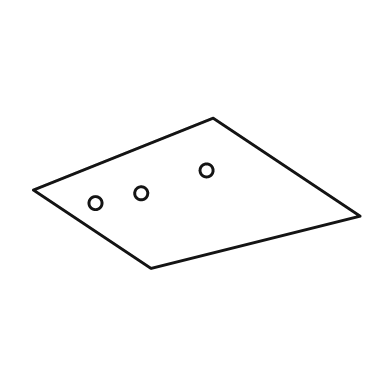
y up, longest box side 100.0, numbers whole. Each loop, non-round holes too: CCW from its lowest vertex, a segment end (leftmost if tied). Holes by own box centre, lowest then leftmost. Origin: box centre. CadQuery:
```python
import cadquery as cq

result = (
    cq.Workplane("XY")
    .moveTo(-14.0, -23.0)
    .lineTo(50.0, -7.0)
    .lineTo(5.0, 23.0)
    .lineTo(-50.0, 1.0)
    .close()
    .moveTo(-31.0, -3.0)
    .circle(2.0)
    .moveTo(-17.0, 0.0)
    .circle(2.0)
    .moveTo(3.0, 7.0)
    .circle(2.0)
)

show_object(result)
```